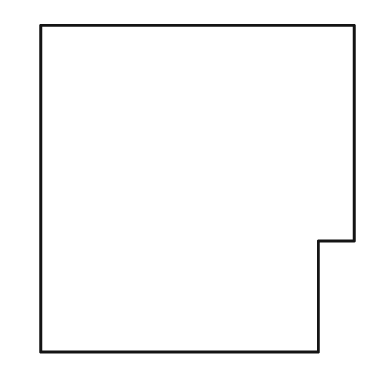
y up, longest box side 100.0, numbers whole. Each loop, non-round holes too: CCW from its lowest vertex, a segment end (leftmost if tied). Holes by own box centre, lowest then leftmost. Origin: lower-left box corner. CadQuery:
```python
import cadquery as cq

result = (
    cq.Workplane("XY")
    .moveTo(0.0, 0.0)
    .lineTo(85.0, 0.0)
    .lineTo(85.0, 34.0)
    .lineTo(96.0, 34.0)
    .lineTo(96.0, 100.0)
    .lineTo(0.0, 100.0)
    .close()
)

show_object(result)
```